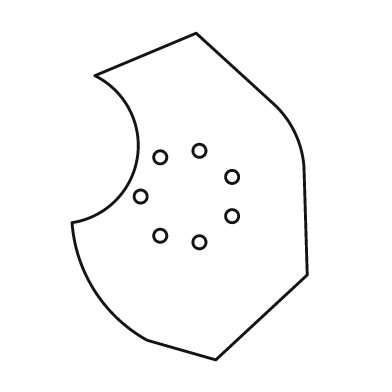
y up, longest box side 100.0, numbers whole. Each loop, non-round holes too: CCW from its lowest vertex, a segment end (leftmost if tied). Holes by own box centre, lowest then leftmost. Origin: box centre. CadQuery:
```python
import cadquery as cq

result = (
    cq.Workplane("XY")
    .moveTo(8.0, -50.0)
    .lineTo(36.0, -24.0)
    .lineTo(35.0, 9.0)
    .threePointArc((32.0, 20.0), (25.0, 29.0))
    .lineTo(2.0, 50.0)
    .lineTo(-29.0, 37.0)
    .threePointArc((-16.0, 12.0), (-36.0, -8.0))
    .threePointArc((-29.0, -29.0), (-13.0, -44.0))
    .close()
    .moveTo(3.0, -14.0)
    .circle(2.0)
    .moveTo(-9.0, -12.0)
    .circle(2.0)
    .moveTo(13.0, -6.0)
    .circle(2.0)
    .moveTo(-15.0, 0.0)
    .circle(2.0)
    .moveTo(13.0, 6.0)
    .circle(2.0)
    .moveTo(-9.0, 12.0)
    .circle(2.0)
    .moveTo(3.0, 14.0)
    .circle(2.0)
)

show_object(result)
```